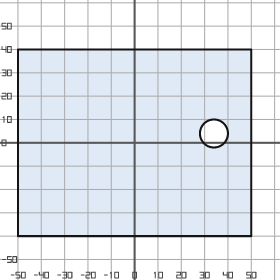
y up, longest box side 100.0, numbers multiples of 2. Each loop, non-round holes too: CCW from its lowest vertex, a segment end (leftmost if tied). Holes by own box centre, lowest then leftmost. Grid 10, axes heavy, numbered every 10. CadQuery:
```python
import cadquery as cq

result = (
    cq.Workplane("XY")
    .moveTo(-50.0, -40.0)
    .lineTo(50.0, -40.0)
    .lineTo(50.0, 40.0)
    .lineTo(-50.0, 40.0)
    .close()
    .moveTo(34.0, 4.0)
    .circle(6.0)
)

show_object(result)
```